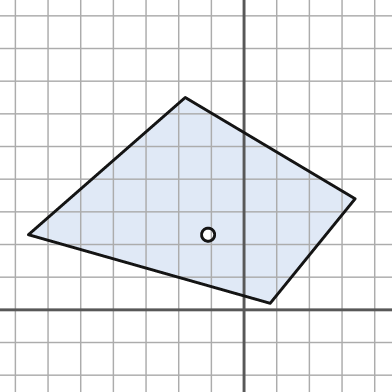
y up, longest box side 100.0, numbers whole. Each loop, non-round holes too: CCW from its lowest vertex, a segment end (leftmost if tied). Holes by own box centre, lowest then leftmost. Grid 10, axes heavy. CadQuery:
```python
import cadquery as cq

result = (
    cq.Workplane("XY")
    .moveTo(8.0, 2.0)
    .lineTo(34.0, 34.0)
    .lineTo(-18.0, 65.0)
    .lineTo(-66.0, 23.0)
    .close()
    .moveTo(-11.0, 23.0)
    .circle(2.0)
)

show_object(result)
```